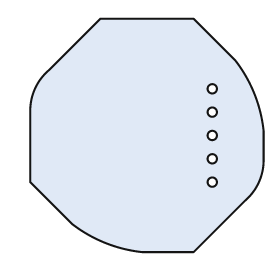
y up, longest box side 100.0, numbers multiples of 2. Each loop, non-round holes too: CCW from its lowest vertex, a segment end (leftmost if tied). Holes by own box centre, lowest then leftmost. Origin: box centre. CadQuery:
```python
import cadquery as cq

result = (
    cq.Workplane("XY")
    .moveTo(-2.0, -50.0)
    .lineTo(20.0, -50.0)
    .lineTo(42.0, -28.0)
    .threePointArc((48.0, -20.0), (50.0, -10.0))
    .lineTo(50.0, 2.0)
    .threePointArc((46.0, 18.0), (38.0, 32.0))
    .lineTo(20.0, 50.0)
    .lineTo(-20.0, 50.0)
    .lineTo(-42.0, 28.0)
    .threePointArc((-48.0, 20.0), (-50.0, 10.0))
    .lineTo(-50.0, -20.0)
    .lineTo(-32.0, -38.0)
    .threePointArc((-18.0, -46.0), (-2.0, -50.0))
    .close()
    .moveTo(28.0, -20.0)
    .circle(2.0)
    .moveTo(28.0, -10.0)
    .circle(2.0)
    .moveTo(28.0, 0.0)
    .circle(2.0)
    .moveTo(28.0, 10.0)
    .circle(2.0)
    .moveTo(28.0, 20.0)
    .circle(2.0)
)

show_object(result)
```